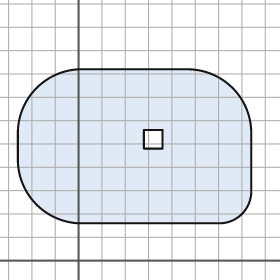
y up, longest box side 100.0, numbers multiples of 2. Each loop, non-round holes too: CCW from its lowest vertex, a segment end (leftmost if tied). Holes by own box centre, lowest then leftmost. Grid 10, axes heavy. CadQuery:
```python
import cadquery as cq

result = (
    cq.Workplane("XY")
    .moveTo(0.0, 16.0)
    .lineTo(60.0, 16.0)
    .threePointArc((70.0, 20.0), (74.0, 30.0))
    .lineTo(74.0, 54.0)
    .threePointArc((66.0, 74.0), (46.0, 82.0))
    .lineTo(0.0, 82.0)
    .threePointArc((-18.0, 74.0), (-26.0, 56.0))
    .lineTo(-26.0, 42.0)
    .threePointArc((-18.0, 24.0), (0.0, 16.0))
    .close()
    .moveTo(28.0, 48.0)
    .lineTo(36.0, 48.0)
    .lineTo(36.0, 56.0)
    .lineTo(28.0, 56.0)
    .close()
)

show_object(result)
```